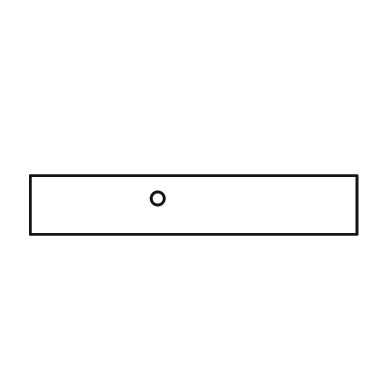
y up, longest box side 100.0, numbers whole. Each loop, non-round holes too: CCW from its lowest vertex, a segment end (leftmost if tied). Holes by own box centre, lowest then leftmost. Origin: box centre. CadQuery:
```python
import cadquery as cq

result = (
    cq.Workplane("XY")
    .moveTo(-50.0, -9.0)
    .lineTo(50.0, -9.0)
    .lineTo(50.0, 9.0)
    .lineTo(-50.0, 9.0)
    .close()
    .moveTo(-11.0, 2.0)
    .circle(2.0)
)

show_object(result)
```